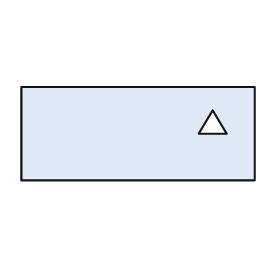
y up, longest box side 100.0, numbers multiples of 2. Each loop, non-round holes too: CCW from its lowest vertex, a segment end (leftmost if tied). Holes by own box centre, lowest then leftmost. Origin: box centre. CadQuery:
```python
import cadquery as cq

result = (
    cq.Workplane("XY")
    .moveTo(-50.0, -20.0)
    .lineTo(50.0, -20.0)
    .lineTo(50.0, 20.0)
    .lineTo(-50.0, 20.0)
    .close()
    .moveTo(26.0, 0.0)
    .lineTo(38.0, 0.0)
    .lineTo(32.0, 10.0)
    .close()
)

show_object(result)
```